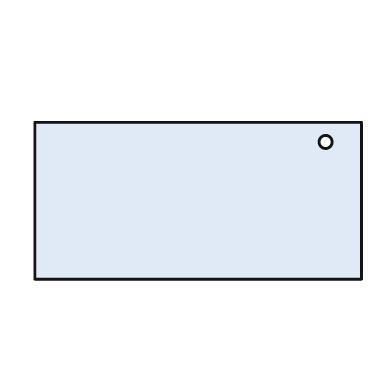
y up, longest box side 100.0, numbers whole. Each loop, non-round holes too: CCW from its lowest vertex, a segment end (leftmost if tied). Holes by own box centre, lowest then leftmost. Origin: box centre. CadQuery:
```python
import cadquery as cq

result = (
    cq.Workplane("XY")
    .moveTo(-50.0, -24.0)
    .lineTo(50.0, -24.0)
    .lineTo(50.0, 24.0)
    .lineTo(-50.0, 24.0)
    .close()
    .moveTo(39.0, 18.0)
    .circle(2.0)
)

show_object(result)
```